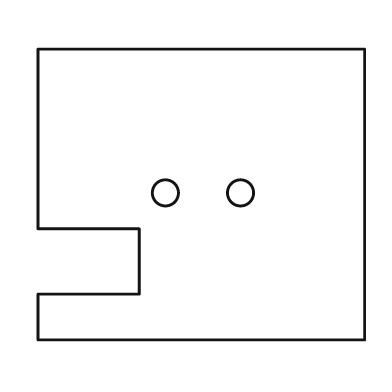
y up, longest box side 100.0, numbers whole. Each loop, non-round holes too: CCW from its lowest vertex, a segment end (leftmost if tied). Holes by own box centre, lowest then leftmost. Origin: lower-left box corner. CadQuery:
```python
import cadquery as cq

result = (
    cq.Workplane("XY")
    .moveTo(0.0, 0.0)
    .lineTo(100.0, 0.0)
    .lineTo(100.0, 89.0)
    .lineTo(0.0, 89.0)
    .lineTo(0.0, 34.0)
    .lineTo(31.0, 34.0)
    .lineTo(31.0, 14.0)
    .lineTo(0.0, 14.0)
    .close()
    .moveTo(39.0, 45.0)
    .circle(4.0)
    .moveTo(62.0, 45.0)
    .circle(4.0)
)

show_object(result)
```